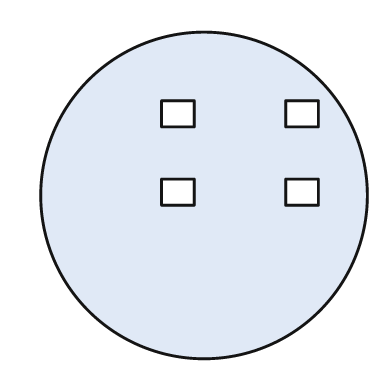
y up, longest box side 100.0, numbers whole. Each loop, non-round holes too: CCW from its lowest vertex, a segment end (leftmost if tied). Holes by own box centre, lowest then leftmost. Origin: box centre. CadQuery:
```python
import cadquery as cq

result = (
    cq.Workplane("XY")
    .moveTo(0.0, 0.0)
    .circle(50.0)
    .moveTo(-13.0, -3.0)
    .lineTo(-3.0, -3.0)
    .lineTo(-3.0, 5.0)
    .lineTo(-13.0, 5.0)
    .close()
    .moveTo(25.0, -3.0)
    .lineTo(35.0, -3.0)
    .lineTo(35.0, 5.0)
    .lineTo(25.0, 5.0)
    .close()
    .moveTo(-13.0, 21.0)
    .lineTo(-3.0, 21.0)
    .lineTo(-3.0, 29.0)
    .lineTo(-13.0, 29.0)
    .close()
    .moveTo(25.0, 21.0)
    .lineTo(35.0, 21.0)
    .lineTo(35.0, 29.0)
    .lineTo(25.0, 29.0)
    .close()
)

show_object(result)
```